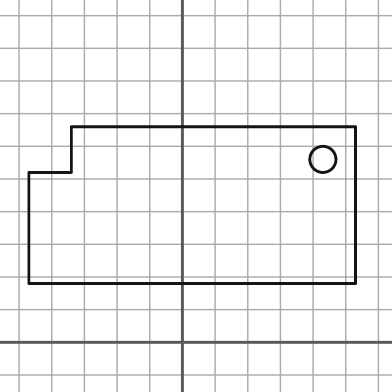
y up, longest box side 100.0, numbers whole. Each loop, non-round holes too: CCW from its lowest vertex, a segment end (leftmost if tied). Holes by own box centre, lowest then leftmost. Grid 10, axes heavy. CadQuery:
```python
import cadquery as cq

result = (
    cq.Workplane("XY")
    .moveTo(-47.0, 18.0)
    .lineTo(53.0, 18.0)
    .lineTo(53.0, 66.0)
    .lineTo(-34.0, 66.0)
    .lineTo(-34.0, 52.0)
    .lineTo(-47.0, 52.0)
    .close()
    .moveTo(43.0, 56.0)
    .circle(4.0)
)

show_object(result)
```